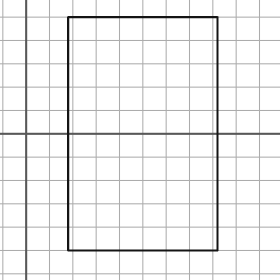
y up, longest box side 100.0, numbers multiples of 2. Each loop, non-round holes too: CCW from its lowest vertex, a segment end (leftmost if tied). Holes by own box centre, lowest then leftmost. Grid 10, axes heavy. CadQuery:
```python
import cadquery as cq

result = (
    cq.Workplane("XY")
    .moveTo(18.0, -50.0)
    .lineTo(82.0, -50.0)
    .lineTo(82.0, 50.0)
    .lineTo(18.0, 50.0)
    .close()
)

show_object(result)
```